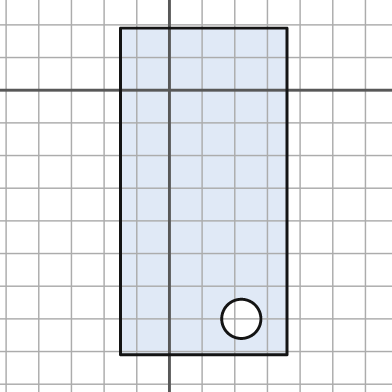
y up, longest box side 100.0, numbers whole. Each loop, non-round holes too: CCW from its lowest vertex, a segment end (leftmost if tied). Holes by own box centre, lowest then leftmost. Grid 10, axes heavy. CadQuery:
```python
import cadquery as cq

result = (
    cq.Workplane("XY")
    .moveTo(-15.0, -81.0)
    .lineTo(36.0, -81.0)
    .lineTo(36.0, 19.0)
    .lineTo(-15.0, 19.0)
    .close()
    .moveTo(22.0, -70.0)
    .circle(6.0)
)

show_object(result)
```